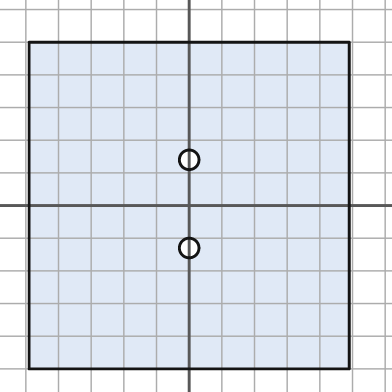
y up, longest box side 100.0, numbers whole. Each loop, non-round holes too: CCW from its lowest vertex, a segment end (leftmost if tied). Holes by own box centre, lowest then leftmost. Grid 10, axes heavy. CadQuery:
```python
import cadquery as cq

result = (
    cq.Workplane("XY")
    .moveTo(-49.0, -50.0)
    .lineTo(49.0, -50.0)
    .lineTo(49.0, 50.0)
    .lineTo(-49.0, 50.0)
    .close()
    .moveTo(0.0, -13.0)
    .circle(3.0)
    .moveTo(0.0, 14.0)
    .circle(3.0)
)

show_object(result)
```